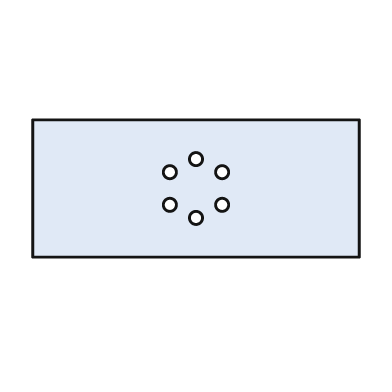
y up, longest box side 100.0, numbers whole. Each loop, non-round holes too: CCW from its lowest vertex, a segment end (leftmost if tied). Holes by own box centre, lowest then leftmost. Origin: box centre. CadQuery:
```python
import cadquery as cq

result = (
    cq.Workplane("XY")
    .moveTo(-50.0, -21.0)
    .lineTo(50.0, -21.0)
    .lineTo(50.0, 21.0)
    .lineTo(-50.0, 21.0)
    .close()
    .moveTo(0.0, -9.0)
    .circle(2.0)
    .moveTo(-8.0, -5.0)
    .circle(2.0)
    .moveTo(8.0, -5.0)
    .circle(2.0)
    .moveTo(-8.0, 5.0)
    .circle(2.0)
    .moveTo(8.0, 5.0)
    .circle(2.0)
    .moveTo(0.0, 9.0)
    .circle(2.0)
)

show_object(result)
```